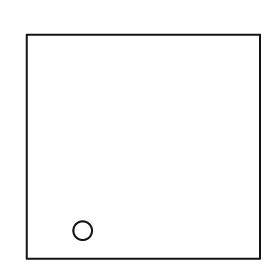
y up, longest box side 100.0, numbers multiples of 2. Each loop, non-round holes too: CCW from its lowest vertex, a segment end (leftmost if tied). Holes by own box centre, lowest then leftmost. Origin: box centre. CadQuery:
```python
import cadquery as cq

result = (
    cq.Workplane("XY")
    .moveTo(-50.0, -48.0)
    .lineTo(50.0, -48.0)
    .lineTo(50.0, 48.0)
    .lineTo(-50.0, 48.0)
    .close()
    .moveTo(-26.0, -36.0)
    .circle(4.0)
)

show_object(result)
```